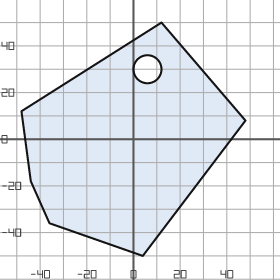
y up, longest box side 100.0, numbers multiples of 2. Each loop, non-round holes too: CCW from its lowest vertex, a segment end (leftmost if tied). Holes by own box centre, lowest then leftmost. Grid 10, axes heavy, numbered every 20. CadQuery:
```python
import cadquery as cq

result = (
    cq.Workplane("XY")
    .moveTo(4.0, -50.0)
    .lineTo(48.0, 8.0)
    .lineTo(12.0, 50.0)
    .lineTo(-48.0, 12.0)
    .lineTo(-44.0, -18.0)
    .lineTo(-36.0, -36.0)
    .close()
    .moveTo(6.0, 30.0)
    .circle(6.0)
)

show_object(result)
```